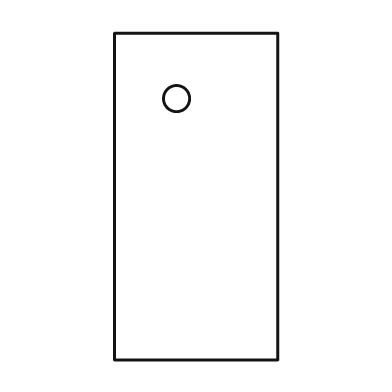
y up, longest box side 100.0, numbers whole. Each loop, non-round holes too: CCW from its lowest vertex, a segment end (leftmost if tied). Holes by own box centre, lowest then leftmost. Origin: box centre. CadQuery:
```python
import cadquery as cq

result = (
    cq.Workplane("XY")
    .moveTo(-25.0, -50.0)
    .lineTo(25.0, -50.0)
    .lineTo(25.0, 50.0)
    .lineTo(-25.0, 50.0)
    .close()
    .moveTo(-6.0, 30.0)
    .circle(4.0)
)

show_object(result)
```